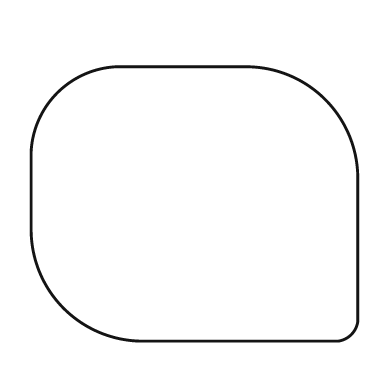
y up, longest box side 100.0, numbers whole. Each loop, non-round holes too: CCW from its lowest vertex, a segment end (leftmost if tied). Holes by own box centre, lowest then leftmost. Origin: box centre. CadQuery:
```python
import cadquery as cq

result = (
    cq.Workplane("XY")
    .moveTo(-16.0, -42.0)
    .lineTo(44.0, -42.0)
    .threePointArc((48.0, -40.0), (50.0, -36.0))
    .lineTo(50.0, 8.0)
    .threePointArc((40.0, 32.0), (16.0, 42.0))
    .lineTo(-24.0, 42.0)
    .threePointArc((-42.0, 34.0), (-50.0, 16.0))
    .lineTo(-50.0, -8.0)
    .threePointArc((-40.0, -32.0), (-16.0, -42.0))
    .close()
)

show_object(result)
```